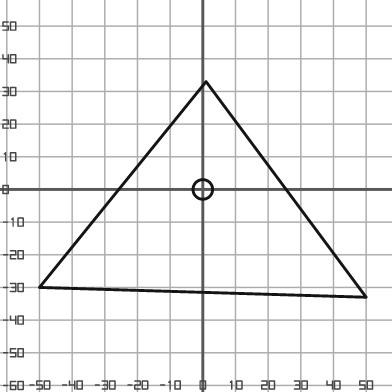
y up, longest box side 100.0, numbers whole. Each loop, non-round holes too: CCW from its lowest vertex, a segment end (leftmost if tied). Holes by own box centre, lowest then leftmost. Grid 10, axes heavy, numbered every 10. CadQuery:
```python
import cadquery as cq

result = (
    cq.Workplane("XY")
    .moveTo(50.0, -33.0)
    .lineTo(1.0, 33.0)
    .lineTo(-50.0, -30.0)
    .close()
    .moveTo(0.0, 0.0)
    .circle(3.0)
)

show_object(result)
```